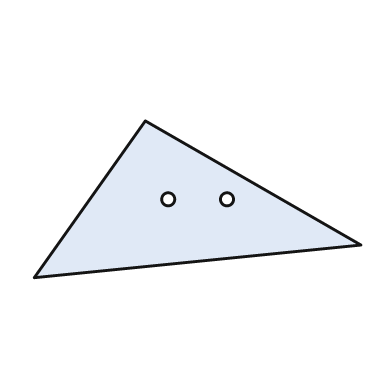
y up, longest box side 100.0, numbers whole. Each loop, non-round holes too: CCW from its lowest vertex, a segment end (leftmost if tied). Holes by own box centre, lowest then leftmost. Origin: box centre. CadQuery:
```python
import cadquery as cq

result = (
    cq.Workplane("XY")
    .moveTo(-50.0, -24.0)
    .lineTo(50.0, -14.0)
    .lineTo(-16.0, 24.0)
    .close()
    .moveTo(-9.0, 0.0)
    .circle(2.0)
    .moveTo(9.0, 0.0)
    .circle(2.0)
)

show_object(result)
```